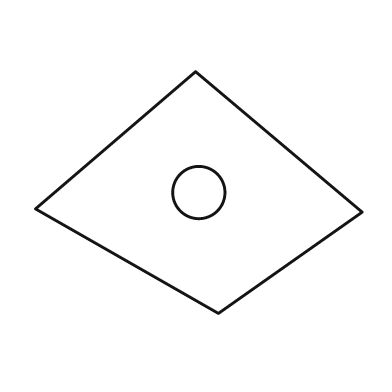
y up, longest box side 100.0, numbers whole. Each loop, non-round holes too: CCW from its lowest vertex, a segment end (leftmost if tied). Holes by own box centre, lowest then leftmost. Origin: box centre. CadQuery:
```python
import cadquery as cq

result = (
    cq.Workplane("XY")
    .moveTo(6.0, -37.0)
    .lineTo(50.0, -6.0)
    .lineTo(-1.0, 37.0)
    .lineTo(-50.0, -5.0)
    .close()
    .moveTo(0.0, 0.0)
    .circle(8.0)
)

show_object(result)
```